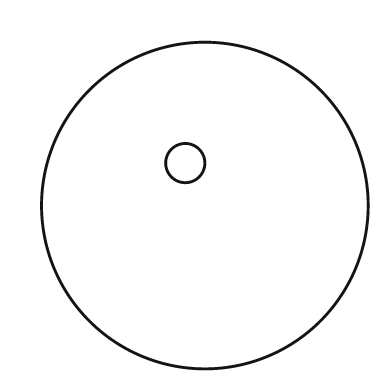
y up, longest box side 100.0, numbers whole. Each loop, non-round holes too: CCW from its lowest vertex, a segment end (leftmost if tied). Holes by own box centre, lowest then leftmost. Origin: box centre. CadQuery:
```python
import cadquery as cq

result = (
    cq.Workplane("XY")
    .moveTo(0.0, 0.0)
    .circle(50.0)
    .moveTo(-6.0, 13.0)
    .circle(6.0)
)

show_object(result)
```